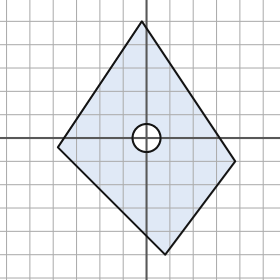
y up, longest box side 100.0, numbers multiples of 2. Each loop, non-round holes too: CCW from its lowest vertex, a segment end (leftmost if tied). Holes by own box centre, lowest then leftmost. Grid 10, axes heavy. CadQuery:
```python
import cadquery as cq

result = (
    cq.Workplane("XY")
    .moveTo(8.0, -50.0)
    .lineTo(38.0, -10.0)
    .lineTo(-2.0, 50.0)
    .lineTo(-38.0, -4.0)
    .close()
    .moveTo(0.0, 0.0)
    .circle(6.0)
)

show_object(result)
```